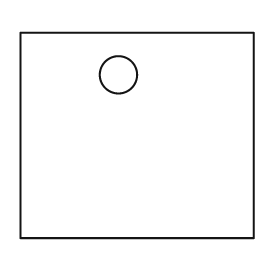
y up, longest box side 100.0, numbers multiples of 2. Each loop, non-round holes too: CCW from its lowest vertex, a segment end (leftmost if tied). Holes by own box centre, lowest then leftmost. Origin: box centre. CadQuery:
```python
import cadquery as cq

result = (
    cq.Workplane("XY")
    .moveTo(-50.0, -44.0)
    .lineTo(50.0, -44.0)
    .lineTo(50.0, 44.0)
    .lineTo(-50.0, 44.0)
    .close()
    .moveTo(-8.0, 26.0)
    .circle(8.0)
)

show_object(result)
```